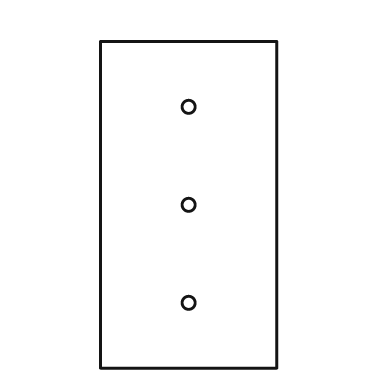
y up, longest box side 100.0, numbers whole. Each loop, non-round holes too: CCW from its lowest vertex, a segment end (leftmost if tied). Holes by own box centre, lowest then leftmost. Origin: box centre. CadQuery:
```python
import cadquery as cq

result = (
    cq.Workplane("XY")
    .moveTo(-27.0, -50.0)
    .lineTo(27.0, -50.0)
    .lineTo(27.0, 50.0)
    .lineTo(-27.0, 50.0)
    .close()
    .moveTo(0.0, -30.0)
    .circle(2.0)
    .moveTo(0.0, 0.0)
    .circle(2.0)
    .moveTo(0.0, 30.0)
    .circle(2.0)
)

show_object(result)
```